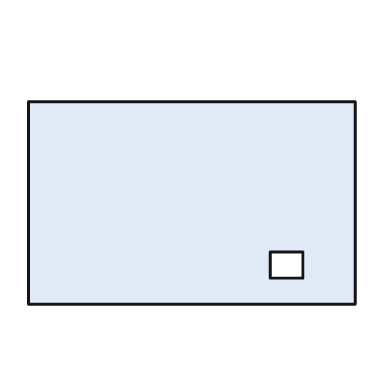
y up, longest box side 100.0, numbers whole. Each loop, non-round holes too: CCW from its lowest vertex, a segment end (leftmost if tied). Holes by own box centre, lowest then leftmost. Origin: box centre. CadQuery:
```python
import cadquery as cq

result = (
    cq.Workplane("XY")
    .moveTo(-50.0, -31.0)
    .lineTo(50.0, -31.0)
    .lineTo(50.0, 31.0)
    .lineTo(-50.0, 31.0)
    .close()
    .moveTo(24.0, -23.0)
    .lineTo(34.0, -23.0)
    .lineTo(34.0, -15.0)
    .lineTo(24.0, -15.0)
    .close()
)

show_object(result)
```